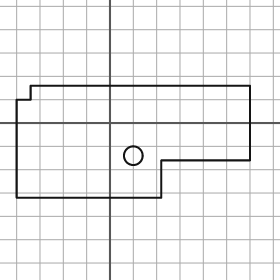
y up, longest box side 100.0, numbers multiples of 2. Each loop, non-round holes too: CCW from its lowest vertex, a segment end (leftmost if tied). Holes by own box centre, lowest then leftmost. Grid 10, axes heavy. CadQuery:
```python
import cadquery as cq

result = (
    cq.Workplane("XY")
    .moveTo(-40.0, -32.0)
    .lineTo(22.0, -32.0)
    .lineTo(22.0, -16.0)
    .lineTo(60.0, -16.0)
    .lineTo(60.0, 16.0)
    .lineTo(-34.0, 16.0)
    .lineTo(-34.0, 10.0)
    .lineTo(-40.0, 10.0)
    .close()
    .moveTo(10.0, -14.0)
    .circle(4.0)
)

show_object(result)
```